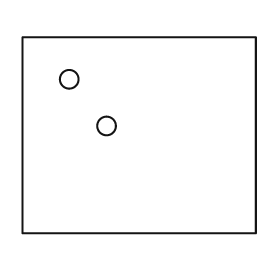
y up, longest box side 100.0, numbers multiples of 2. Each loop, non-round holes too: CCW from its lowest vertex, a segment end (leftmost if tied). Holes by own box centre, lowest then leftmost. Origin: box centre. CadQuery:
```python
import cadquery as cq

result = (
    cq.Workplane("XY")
    .moveTo(-50.0, -42.0)
    .lineTo(50.0, -42.0)
    .lineTo(50.0, 42.0)
    .lineTo(-50.0, 42.0)
    .close()
    .moveTo(-14.0, 4.0)
    .circle(4.0)
    .moveTo(-30.0, 24.0)
    .circle(4.0)
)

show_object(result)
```